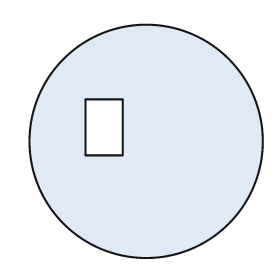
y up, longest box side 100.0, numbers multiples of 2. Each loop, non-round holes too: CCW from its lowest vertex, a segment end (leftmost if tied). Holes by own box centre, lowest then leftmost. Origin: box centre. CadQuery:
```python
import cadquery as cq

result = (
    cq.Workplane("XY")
    .moveTo(0.0, 0.0)
    .circle(50.0)
    .moveTo(-26.0, -6.0)
    .lineTo(-10.0, -6.0)
    .lineTo(-10.0, 18.0)
    .lineTo(-26.0, 18.0)
    .close()
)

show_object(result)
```